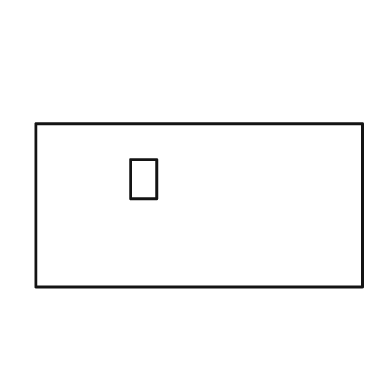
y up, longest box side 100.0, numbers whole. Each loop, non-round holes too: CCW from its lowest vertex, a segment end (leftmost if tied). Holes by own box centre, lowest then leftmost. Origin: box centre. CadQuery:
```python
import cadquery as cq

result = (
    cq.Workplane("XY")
    .moveTo(-50.0, -25.0)
    .lineTo(50.0, -25.0)
    .lineTo(50.0, 25.0)
    .lineTo(-50.0, 25.0)
    .close()
    .moveTo(-21.0, 2.0)
    .lineTo(-13.0, 2.0)
    .lineTo(-13.0, 14.0)
    .lineTo(-21.0, 14.0)
    .close()
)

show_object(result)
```